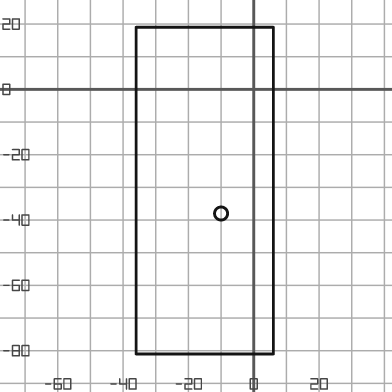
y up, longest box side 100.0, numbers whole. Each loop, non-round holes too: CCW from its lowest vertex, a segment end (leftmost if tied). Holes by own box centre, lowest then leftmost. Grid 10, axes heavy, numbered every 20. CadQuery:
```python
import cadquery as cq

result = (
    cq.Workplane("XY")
    .moveTo(-36.0, -81.0)
    .lineTo(6.0, -81.0)
    .lineTo(6.0, 19.0)
    .lineTo(-36.0, 19.0)
    .close()
    .moveTo(-10.0, -38.0)
    .circle(2.0)
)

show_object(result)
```